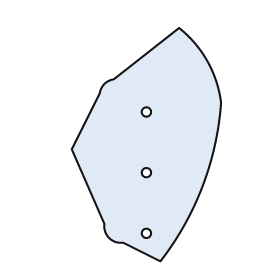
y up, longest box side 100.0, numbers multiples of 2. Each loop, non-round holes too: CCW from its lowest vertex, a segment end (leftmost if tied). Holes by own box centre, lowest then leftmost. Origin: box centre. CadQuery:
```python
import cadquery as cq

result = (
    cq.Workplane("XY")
    .moveTo(6.0, -50.0)
    .threePointArc((24.0, -18.0), (32.0, 18.0))
    .threePointArc((26.0, 36.0), (14.0, 50.0))
    .lineTo(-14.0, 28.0)
    .threePointArc((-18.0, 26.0), (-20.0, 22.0))
    .lineTo(-32.0, -2.0)
    .lineTo(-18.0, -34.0)
    .threePointArc((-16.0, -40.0), (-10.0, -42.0))
    .close()
    .moveTo(0.0, -38.0)
    .circle(2.0)
    .moveTo(0.0, -12.0)
    .circle(2.0)
    .moveTo(0.0, 14.0)
    .circle(2.0)
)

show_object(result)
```